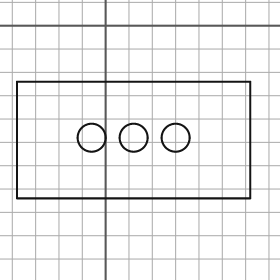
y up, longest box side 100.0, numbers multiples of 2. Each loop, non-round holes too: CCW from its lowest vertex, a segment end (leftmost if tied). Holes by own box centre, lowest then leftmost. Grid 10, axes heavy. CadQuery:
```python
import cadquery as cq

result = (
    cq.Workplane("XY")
    .moveTo(-38.0, -74.0)
    .lineTo(62.0, -74.0)
    .lineTo(62.0, -24.0)
    .lineTo(-38.0, -24.0)
    .close()
    .moveTo(-6.0, -48.0)
    .circle(6.0)
    .moveTo(12.0, -48.0)
    .circle(6.0)
    .moveTo(30.0, -48.0)
    .circle(6.0)
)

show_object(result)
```